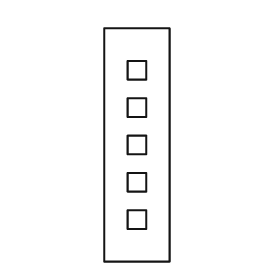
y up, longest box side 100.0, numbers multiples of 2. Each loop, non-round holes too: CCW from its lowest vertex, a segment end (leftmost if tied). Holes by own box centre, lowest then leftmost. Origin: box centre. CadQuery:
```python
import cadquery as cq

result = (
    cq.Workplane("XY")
    .moveTo(-14.0, -50.0)
    .lineTo(14.0, -50.0)
    .lineTo(14.0, 50.0)
    .lineTo(-14.0, 50.0)
    .close()
    .moveTo(-4.0, -36.0)
    .lineTo(4.0, -36.0)
    .lineTo(4.0, -28.0)
    .lineTo(-4.0, -28.0)
    .close()
    .moveTo(-4.0, -20.0)
    .lineTo(4.0, -20.0)
    .lineTo(4.0, -12.0)
    .lineTo(-4.0, -12.0)
    .close()
    .moveTo(-4.0, -4.0)
    .lineTo(4.0, -4.0)
    .lineTo(4.0, 4.0)
    .lineTo(-4.0, 4.0)
    .close()
    .moveTo(-4.0, 12.0)
    .lineTo(4.0, 12.0)
    .lineTo(4.0, 20.0)
    .lineTo(-4.0, 20.0)
    .close()
    .moveTo(-4.0, 28.0)
    .lineTo(4.0, 28.0)
    .lineTo(4.0, 36.0)
    .lineTo(-4.0, 36.0)
    .close()
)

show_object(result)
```